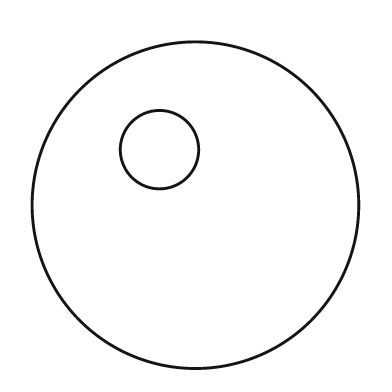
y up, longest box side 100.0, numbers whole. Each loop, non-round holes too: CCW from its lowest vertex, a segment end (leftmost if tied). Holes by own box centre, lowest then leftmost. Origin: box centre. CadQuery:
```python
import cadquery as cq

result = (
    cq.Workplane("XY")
    .moveTo(0.0, 0.0)
    .circle(50.0)
    .moveTo(-11.0, 17.0)
    .circle(12.0)
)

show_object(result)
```